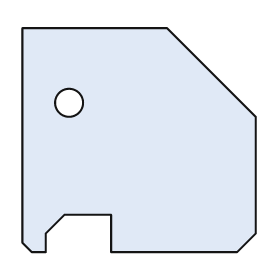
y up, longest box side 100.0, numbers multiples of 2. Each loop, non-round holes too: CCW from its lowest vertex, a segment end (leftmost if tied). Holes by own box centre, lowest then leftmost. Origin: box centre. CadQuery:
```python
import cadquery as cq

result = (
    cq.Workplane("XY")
    .moveTo(-46.0, -48.0)
    .lineTo(-40.0, -48.0)
    .lineTo(-40.0, -40.0)
    .lineTo(-32.0, -32.0)
    .lineTo(-12.0, -32.0)
    .lineTo(-12.0, -48.0)
    .lineTo(42.0, -48.0)
    .lineTo(50.0, -40.0)
    .lineTo(50.0, 10.0)
    .lineTo(12.0, 48.0)
    .lineTo(-50.0, 48.0)
    .lineTo(-50.0, -44.0)
    .close()
    .moveTo(-30.0, 16.0)
    .circle(6.0)
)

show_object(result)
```